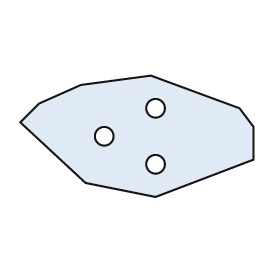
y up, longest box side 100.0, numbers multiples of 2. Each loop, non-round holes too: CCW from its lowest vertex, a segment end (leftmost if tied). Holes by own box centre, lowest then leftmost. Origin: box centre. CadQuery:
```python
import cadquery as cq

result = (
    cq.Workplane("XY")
    .moveTo(8.0, -26.0)
    .lineTo(50.0, -10.0)
    .lineTo(50.0, 4.0)
    .lineTo(44.0, 12.0)
    .lineTo(6.0, 26.0)
    .lineTo(-24.0, 22.0)
    .lineTo(-42.0, 14.0)
    .lineTo(-50.0, 6.0)
    .lineTo(-22.0, -20.0)
    .close()
    .moveTo(8.0, -12.0)
    .circle(4.0)
    .moveTo(-14.0, 0.0)
    .circle(4.0)
    .moveTo(8.0, 12.0)
    .circle(4.0)
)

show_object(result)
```